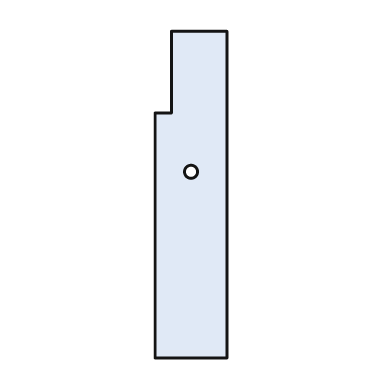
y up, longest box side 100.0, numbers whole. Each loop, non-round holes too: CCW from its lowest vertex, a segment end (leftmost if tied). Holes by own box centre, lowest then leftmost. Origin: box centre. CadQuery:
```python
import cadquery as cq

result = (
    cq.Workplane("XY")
    .moveTo(-11.0, -50.0)
    .lineTo(11.0, -50.0)
    .lineTo(11.0, 50.0)
    .lineTo(-6.0, 50.0)
    .lineTo(-6.0, 25.0)
    .lineTo(-11.0, 25.0)
    .close()
    .moveTo(0.0, 7.0)
    .circle(2.0)
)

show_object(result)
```